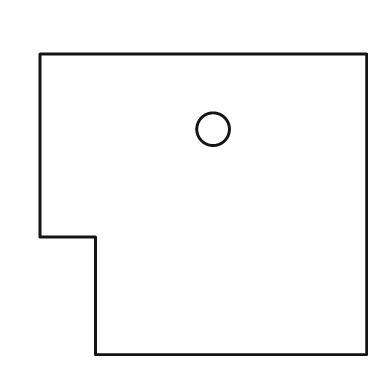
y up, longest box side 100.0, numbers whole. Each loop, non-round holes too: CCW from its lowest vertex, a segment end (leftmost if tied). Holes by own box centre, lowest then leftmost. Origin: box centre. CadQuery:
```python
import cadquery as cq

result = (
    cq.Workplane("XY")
    .moveTo(-33.0, -46.0)
    .lineTo(50.0, -46.0)
    .lineTo(50.0, 46.0)
    .lineTo(-50.0, 46.0)
    .lineTo(-50.0, -10.0)
    .lineTo(-33.0, -10.0)
    .close()
    .moveTo(3.0, 23.0)
    .circle(5.0)
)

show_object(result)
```